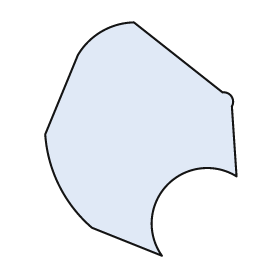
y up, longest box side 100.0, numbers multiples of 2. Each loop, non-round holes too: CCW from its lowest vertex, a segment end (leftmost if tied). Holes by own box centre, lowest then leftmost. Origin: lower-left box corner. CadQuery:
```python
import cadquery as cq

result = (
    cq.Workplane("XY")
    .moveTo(50.0, 0.0)
    .threePointArc((52.0, 30.0), (82.0, 34.0))
    .lineTo(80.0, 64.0)
    .threePointArc((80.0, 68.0), (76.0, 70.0))
    .lineTo(38.0, 100.0)
    .threePointArc((24.0, 96.0), (14.0, 86.0))
    .lineTo(0.0, 52.0)
    .threePointArc((6.0, 30.0), (20.0, 12.0))
    .close()
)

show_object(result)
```